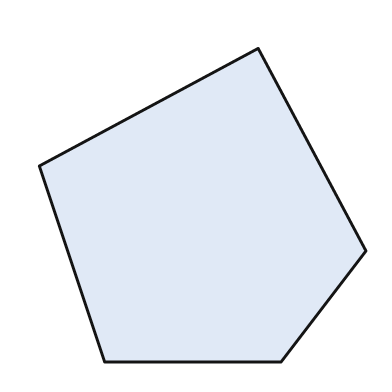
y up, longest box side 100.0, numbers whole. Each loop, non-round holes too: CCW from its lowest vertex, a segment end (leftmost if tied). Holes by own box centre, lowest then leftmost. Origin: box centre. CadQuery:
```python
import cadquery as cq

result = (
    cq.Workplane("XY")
    .moveTo(-30.0, -48.0)
    .lineTo(24.0, -48.0)
    .lineTo(50.0, -14.0)
    .lineTo(17.0, 48.0)
    .lineTo(-50.0, 12.0)
    .close()
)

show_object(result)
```